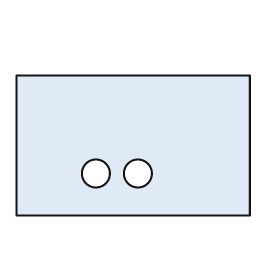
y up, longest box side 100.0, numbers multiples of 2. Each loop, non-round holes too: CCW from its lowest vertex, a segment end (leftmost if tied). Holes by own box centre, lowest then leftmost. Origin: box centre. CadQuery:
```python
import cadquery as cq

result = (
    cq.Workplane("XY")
    .moveTo(-50.0, -30.0)
    .lineTo(50.0, -30.0)
    .lineTo(50.0, 30.0)
    .lineTo(-50.0, 30.0)
    .close()
    .moveTo(-16.0, -12.0)
    .circle(6.0)
    .moveTo(2.0, -12.0)
    .circle(6.0)
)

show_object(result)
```